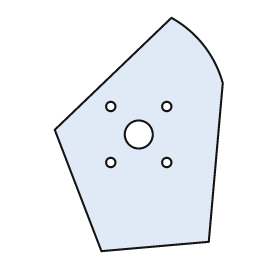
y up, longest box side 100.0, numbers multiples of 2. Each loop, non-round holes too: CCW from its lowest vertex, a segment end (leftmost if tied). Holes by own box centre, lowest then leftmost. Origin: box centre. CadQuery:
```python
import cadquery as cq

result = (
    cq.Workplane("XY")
    .moveTo(-16.0, -50.0)
    .lineTo(30.0, -46.0)
    .lineTo(36.0, 22.0)
    .threePointArc((28.0, 38.0), (14.0, 50.0))
    .lineTo(-36.0, 2.0)
    .close()
    .moveTo(-12.0, -12.0)
    .circle(2.0)
    .moveTo(12.0, -12.0)
    .circle(2.0)
    .moveTo(0.0, 0.0)
    .circle(6.0)
    .moveTo(-12.0, 12.0)
    .circle(2.0)
    .moveTo(12.0, 12.0)
    .circle(2.0)
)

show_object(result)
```